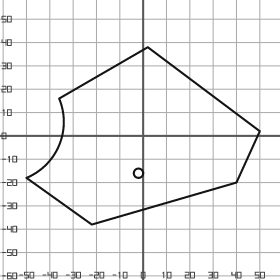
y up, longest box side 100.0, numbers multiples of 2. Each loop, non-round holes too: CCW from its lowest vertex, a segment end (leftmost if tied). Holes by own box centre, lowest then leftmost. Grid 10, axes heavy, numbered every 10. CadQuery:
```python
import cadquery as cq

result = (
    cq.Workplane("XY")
    .moveTo(-22.0, -38.0)
    .lineTo(40.0, -20.0)
    .lineTo(50.0, 2.0)
    .lineTo(2.0, 38.0)
    .lineTo(-36.0, 16.0)
    .threePointArc((-36.0, -4.0), (-50.0, -18.0))
    .close()
    .moveTo(-2.0, -16.0)
    .circle(2.0)
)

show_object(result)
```